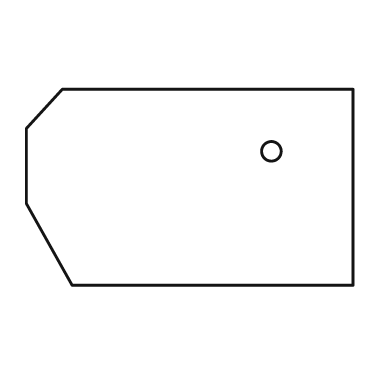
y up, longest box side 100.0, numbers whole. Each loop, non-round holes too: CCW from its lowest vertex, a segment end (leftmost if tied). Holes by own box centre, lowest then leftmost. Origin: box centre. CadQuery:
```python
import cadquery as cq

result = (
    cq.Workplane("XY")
    .moveTo(-36.0, -30.0)
    .lineTo(50.0, -30.0)
    .lineTo(50.0, 30.0)
    .lineTo(-39.0, 30.0)
    .lineTo(-50.0, 18.0)
    .lineTo(-50.0, -5.0)
    .close()
    .moveTo(25.0, 11.0)
    .circle(3.0)
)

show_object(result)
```